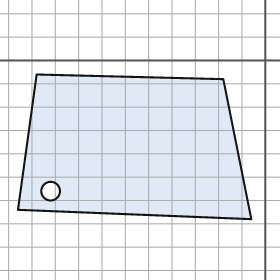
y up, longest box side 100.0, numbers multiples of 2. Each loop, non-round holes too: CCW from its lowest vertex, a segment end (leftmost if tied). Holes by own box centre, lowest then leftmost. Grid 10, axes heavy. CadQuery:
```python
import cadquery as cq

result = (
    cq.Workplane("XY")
    .moveTo(-6.0, -68.0)
    .lineTo(-18.0, -8.0)
    .lineTo(-98.0, -6.0)
    .lineTo(-106.0, -64.0)
    .close()
    .moveTo(-92.0, -56.0)
    .circle(4.0)
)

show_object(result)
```